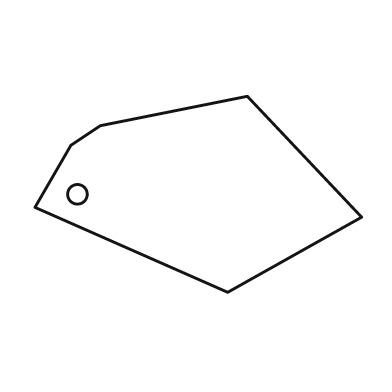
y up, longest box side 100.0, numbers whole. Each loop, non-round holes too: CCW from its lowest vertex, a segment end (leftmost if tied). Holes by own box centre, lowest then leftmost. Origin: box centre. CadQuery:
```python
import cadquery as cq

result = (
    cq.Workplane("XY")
    .moveTo(9.0, -30.0)
    .lineTo(50.0, -7.0)
    .lineTo(15.0, 30.0)
    .lineTo(-30.0, 21.0)
    .lineTo(-39.0, 15.0)
    .lineTo(-50.0, -4.0)
    .close()
    .moveTo(-37.0, 0.0)
    .circle(3.0)
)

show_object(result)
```